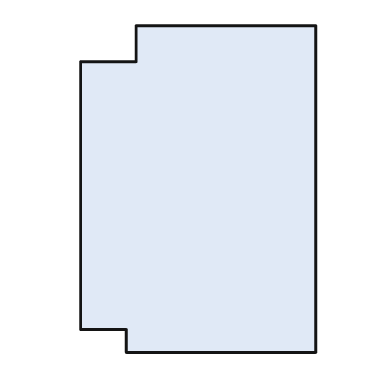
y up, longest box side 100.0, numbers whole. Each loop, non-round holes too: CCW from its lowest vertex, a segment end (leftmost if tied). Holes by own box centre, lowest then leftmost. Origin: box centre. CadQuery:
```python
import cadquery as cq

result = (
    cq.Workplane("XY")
    .moveTo(-22.0, -50.0)
    .lineTo(36.0, -50.0)
    .lineTo(36.0, 50.0)
    .lineTo(-19.0, 50.0)
    .lineTo(-19.0, 39.0)
    .lineTo(-36.0, 39.0)
    .lineTo(-36.0, -43.0)
    .lineTo(-22.0, -43.0)
    .close()
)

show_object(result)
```